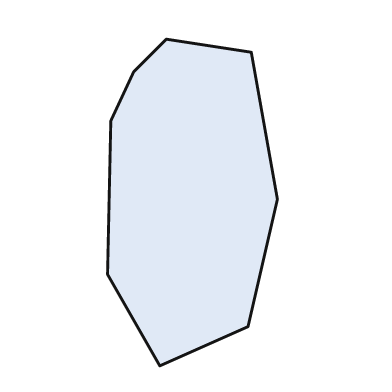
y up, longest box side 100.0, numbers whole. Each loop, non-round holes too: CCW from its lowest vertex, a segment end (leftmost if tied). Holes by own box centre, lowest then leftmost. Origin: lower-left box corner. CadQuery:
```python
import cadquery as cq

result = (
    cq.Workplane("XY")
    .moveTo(16.0, 0.0)
    .lineTo(43.0, 12.0)
    .lineTo(52.0, 51.0)
    .lineTo(44.0, 96.0)
    .lineTo(18.0, 100.0)
    .lineTo(8.0, 90.0)
    .lineTo(1.0, 75.0)
    .lineTo(0.0, 28.0)
    .close()
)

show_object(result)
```